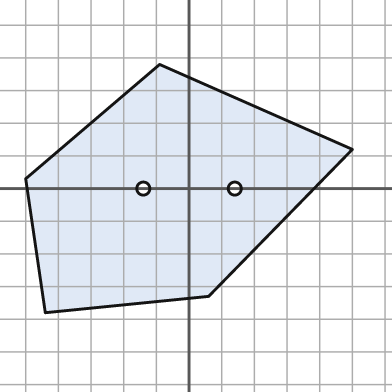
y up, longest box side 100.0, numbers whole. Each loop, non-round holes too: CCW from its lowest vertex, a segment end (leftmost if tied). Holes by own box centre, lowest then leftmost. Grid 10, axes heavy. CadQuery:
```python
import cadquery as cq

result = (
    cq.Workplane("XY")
    .moveTo(-44.0, -38.0)
    .lineTo(6.0, -33.0)
    .lineTo(50.0, 12.0)
    .lineTo(-9.0, 38.0)
    .lineTo(-50.0, 3.0)
    .close()
    .moveTo(-14.0, 0.0)
    .circle(2.0)
    .moveTo(14.0, 0.0)
    .circle(2.0)
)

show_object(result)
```